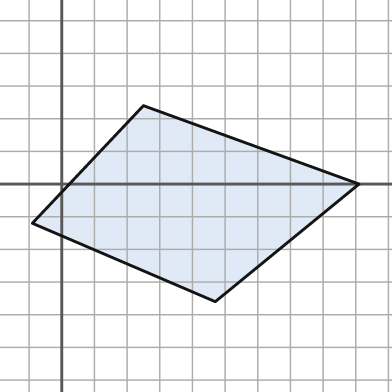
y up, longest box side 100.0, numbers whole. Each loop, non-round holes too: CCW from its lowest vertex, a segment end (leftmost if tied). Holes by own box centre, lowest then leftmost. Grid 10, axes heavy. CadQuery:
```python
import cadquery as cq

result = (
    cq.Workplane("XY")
    .moveTo(47.0, -36.0)
    .lineTo(91.0, 0.0)
    .lineTo(25.0, 24.0)
    .lineTo(-9.0, -12.0)
    .close()
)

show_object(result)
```